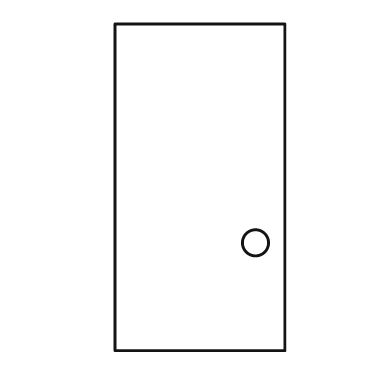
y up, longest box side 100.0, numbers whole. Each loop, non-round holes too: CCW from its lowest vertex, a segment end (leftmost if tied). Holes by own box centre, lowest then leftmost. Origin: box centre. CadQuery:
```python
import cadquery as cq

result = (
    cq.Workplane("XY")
    .moveTo(-26.0, -50.0)
    .lineTo(26.0, -50.0)
    .lineTo(26.0, 50.0)
    .lineTo(-26.0, 50.0)
    .close()
    .moveTo(17.0, -17.0)
    .circle(4.0)
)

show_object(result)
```